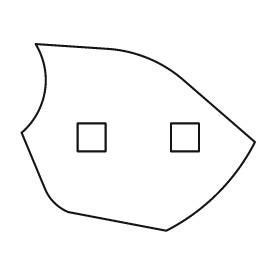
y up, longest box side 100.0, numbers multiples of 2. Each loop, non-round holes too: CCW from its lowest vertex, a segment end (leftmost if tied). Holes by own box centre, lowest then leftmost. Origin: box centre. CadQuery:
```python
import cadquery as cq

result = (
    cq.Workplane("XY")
    .moveTo(12.0, -40.0)
    .threePointArc((34.0, -24.0), (50.0, -2.0))
    .lineTo(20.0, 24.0)
    .threePointArc((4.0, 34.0), (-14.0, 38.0))
    .lineTo(-44.0, 40.0)
    .threePointArc((-40.0, 20.0), (-50.0, 2.0))
    .lineTo(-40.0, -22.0)
    .threePointArc((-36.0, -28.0), (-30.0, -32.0))
    .close()
    .moveTo(-26.0, -6.0)
    .lineTo(-14.0, -6.0)
    .lineTo(-14.0, 6.0)
    .lineTo(-26.0, 6.0)
    .close()
    .moveTo(14.0, -6.0)
    .lineTo(26.0, -6.0)
    .lineTo(26.0, 6.0)
    .lineTo(14.0, 6.0)
    .close()
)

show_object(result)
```